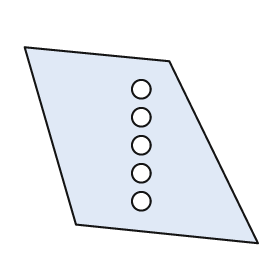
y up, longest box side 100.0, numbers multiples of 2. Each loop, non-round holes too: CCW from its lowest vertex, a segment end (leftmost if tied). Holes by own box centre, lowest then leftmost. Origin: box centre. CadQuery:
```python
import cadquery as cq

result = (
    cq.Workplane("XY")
    .moveTo(50.0, -42.0)
    .lineTo(12.0, 36.0)
    .lineTo(-50.0, 42.0)
    .lineTo(-28.0, -34.0)
    .close()
    .moveTo(0.0, -24.0)
    .circle(4.0)
    .moveTo(0.0, -12.0)
    .circle(4.0)
    .moveTo(0.0, 0.0)
    .circle(4.0)
    .moveTo(0.0, 12.0)
    .circle(4.0)
    .moveTo(0.0, 24.0)
    .circle(4.0)
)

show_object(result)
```